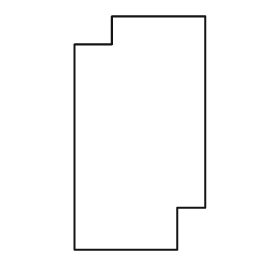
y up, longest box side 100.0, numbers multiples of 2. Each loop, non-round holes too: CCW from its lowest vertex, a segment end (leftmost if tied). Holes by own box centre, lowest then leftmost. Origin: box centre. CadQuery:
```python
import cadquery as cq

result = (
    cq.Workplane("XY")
    .moveTo(-28.0, -50.0)
    .lineTo(16.0, -50.0)
    .lineTo(16.0, -32.0)
    .lineTo(28.0, -32.0)
    .lineTo(28.0, 50.0)
    .lineTo(-12.0, 50.0)
    .lineTo(-12.0, 38.0)
    .lineTo(-28.0, 38.0)
    .close()
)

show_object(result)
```